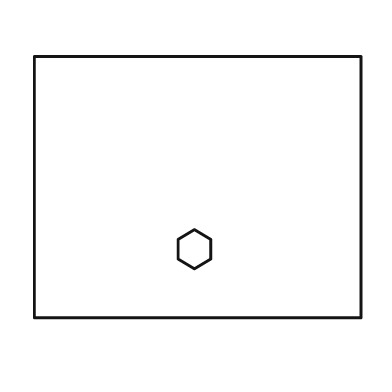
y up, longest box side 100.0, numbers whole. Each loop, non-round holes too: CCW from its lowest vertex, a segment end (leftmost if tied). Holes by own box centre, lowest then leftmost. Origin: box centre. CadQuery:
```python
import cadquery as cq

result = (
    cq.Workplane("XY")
    .moveTo(-50.0, -40.0)
    .lineTo(50.0, -40.0)
    .lineTo(50.0, 40.0)
    .lineTo(-50.0, 40.0)
    .close()
    .moveTo(-1.0, -25.0)
    .lineTo(4.0, -22.0)
    .lineTo(4.0, -16.0)
    .lineTo(-1.0, -13.0)
    .lineTo(-6.0, -16.0)
    .lineTo(-6.0, -22.0)
    .close()
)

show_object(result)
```